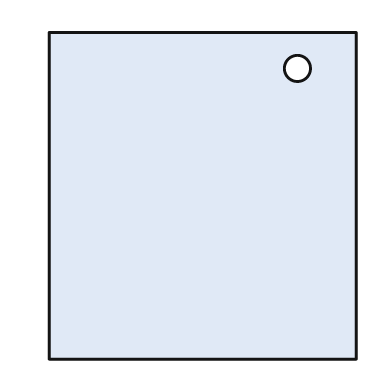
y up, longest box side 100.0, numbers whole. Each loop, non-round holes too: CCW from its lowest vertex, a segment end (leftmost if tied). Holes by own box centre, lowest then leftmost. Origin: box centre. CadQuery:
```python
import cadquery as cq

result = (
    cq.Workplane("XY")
    .moveTo(-47.0, -50.0)
    .lineTo(47.0, -50.0)
    .lineTo(47.0, 50.0)
    .lineTo(-47.0, 50.0)
    .close()
    .moveTo(29.0, 39.0)
    .circle(4.0)
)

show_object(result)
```